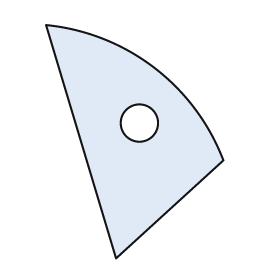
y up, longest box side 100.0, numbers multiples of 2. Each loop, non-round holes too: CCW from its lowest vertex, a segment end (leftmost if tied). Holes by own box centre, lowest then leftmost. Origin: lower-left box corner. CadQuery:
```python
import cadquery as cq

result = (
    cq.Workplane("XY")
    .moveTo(30.0, 0.0)
    .lineTo(76.0, 42.0)
    .threePointArc((46.0, 82.0), (0.0, 100.0))
    .close()
    .moveTo(40.0, 58.0)
    .circle(8.0)
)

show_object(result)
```